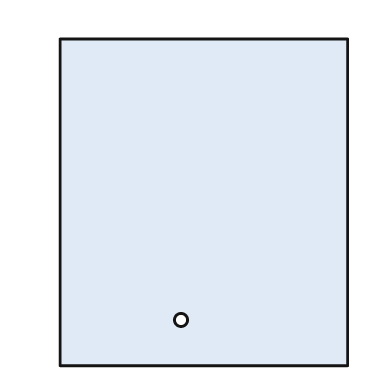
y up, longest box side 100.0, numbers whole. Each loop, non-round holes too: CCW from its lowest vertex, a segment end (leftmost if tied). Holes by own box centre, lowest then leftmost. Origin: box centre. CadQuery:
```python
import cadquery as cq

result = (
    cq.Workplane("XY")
    .moveTo(-44.0, -50.0)
    .lineTo(44.0, -50.0)
    .lineTo(44.0, 50.0)
    .lineTo(-44.0, 50.0)
    .close()
    .moveTo(-7.0, -36.0)
    .circle(2.0)
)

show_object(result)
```